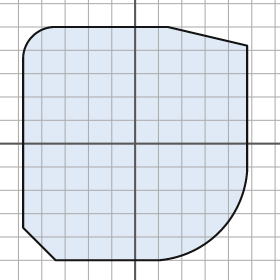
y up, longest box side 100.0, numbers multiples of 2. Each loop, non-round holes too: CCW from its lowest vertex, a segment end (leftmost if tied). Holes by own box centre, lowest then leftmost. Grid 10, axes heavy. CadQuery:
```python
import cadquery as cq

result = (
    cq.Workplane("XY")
    .moveTo(-34.0, -50.0)
    .lineTo(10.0, -50.0)
    .threePointArc((36.0, -38.0), (48.0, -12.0))
    .lineTo(48.0, 42.0)
    .lineTo(14.0, 50.0)
    .lineTo(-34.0, 50.0)
    .threePointArc((-44.0, 46.0), (-48.0, 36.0))
    .lineTo(-48.0, -36.0)
    .close()
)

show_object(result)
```